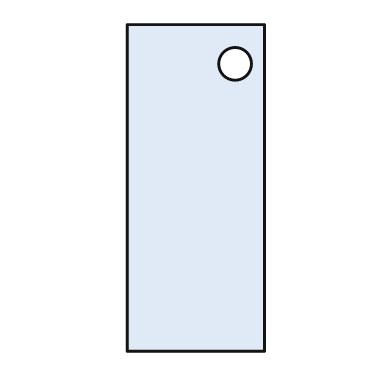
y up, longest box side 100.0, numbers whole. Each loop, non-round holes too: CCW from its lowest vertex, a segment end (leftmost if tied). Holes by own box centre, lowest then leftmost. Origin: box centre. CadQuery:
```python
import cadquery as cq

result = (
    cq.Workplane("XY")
    .moveTo(-21.0, -50.0)
    .lineTo(21.0, -50.0)
    .lineTo(21.0, 50.0)
    .lineTo(-21.0, 50.0)
    .close()
    .moveTo(12.0, 38.0)
    .circle(5.0)
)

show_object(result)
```